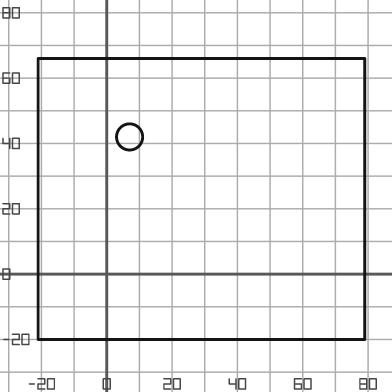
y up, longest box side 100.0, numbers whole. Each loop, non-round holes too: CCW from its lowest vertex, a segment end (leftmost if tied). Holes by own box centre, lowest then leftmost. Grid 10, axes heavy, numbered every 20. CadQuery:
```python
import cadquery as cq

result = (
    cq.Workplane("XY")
    .moveTo(-21.0, -20.0)
    .lineTo(79.0, -20.0)
    .lineTo(79.0, 66.0)
    .lineTo(-21.0, 66.0)
    .close()
    .moveTo(7.0, 42.0)
    .circle(4.0)
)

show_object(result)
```